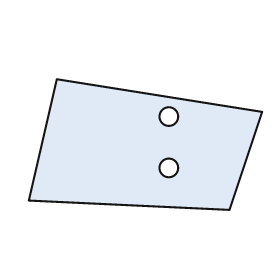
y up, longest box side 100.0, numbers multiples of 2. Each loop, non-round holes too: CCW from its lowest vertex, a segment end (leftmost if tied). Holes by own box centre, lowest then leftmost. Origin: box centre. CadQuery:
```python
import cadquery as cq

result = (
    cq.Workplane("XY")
    .moveTo(36.0, -28.0)
    .lineTo(50.0, 14.0)
    .lineTo(-38.0, 28.0)
    .lineTo(-50.0, -24.0)
    .close()
    .moveTo(10.0, -10.0)
    .circle(4.0)
    .moveTo(10.0, 12.0)
    .circle(4.0)
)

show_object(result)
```